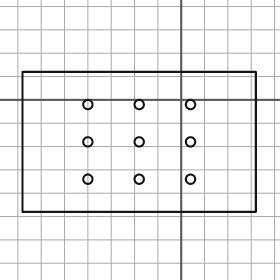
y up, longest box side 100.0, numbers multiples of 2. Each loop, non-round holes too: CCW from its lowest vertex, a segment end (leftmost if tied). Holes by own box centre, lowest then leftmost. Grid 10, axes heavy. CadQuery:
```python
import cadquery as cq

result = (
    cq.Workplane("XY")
    .moveTo(-68.0, -48.0)
    .lineTo(32.0, -48.0)
    .lineTo(32.0, 12.0)
    .lineTo(-68.0, 12.0)
    .close()
    .moveTo(-40.0, -34.0)
    .circle(2.0)
    .moveTo(-18.0, -34.0)
    .circle(2.0)
    .moveTo(4.0, -34.0)
    .circle(2.0)
    .moveTo(-40.0, -18.0)
    .circle(2.0)
    .moveTo(-18.0, -18.0)
    .circle(2.0)
    .moveTo(4.0, -18.0)
    .circle(2.0)
    .moveTo(-40.0, -2.0)
    .circle(2.0)
    .moveTo(-18.0, -2.0)
    .circle(2.0)
    .moveTo(4.0, -2.0)
    .circle(2.0)
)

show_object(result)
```